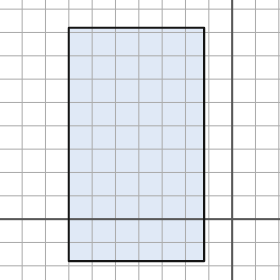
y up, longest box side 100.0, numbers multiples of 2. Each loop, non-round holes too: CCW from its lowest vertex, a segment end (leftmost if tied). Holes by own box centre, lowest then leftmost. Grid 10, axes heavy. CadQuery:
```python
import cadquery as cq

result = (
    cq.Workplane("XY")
    .moveTo(-70.0, -18.0)
    .lineTo(-12.0, -18.0)
    .lineTo(-12.0, 82.0)
    .lineTo(-70.0, 82.0)
    .close()
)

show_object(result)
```